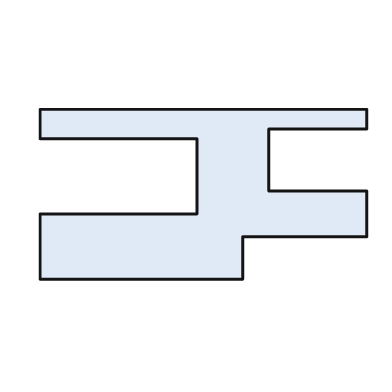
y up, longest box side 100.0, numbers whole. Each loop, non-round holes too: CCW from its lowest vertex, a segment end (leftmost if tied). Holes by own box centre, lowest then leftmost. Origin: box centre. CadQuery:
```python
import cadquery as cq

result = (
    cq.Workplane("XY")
    .moveTo(-50.0, -26.0)
    .lineTo(12.0, -26.0)
    .lineTo(12.0, -13.0)
    .lineTo(50.0, -13.0)
    .lineTo(50.0, 1.0)
    .lineTo(20.0, 1.0)
    .lineTo(20.0, 20.0)
    .lineTo(50.0, 20.0)
    .lineTo(50.0, 26.0)
    .lineTo(-50.0, 26.0)
    .lineTo(-50.0, 17.0)
    .lineTo(-2.0, 17.0)
    .lineTo(-2.0, -6.0)
    .lineTo(-50.0, -6.0)
    .close()
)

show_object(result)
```